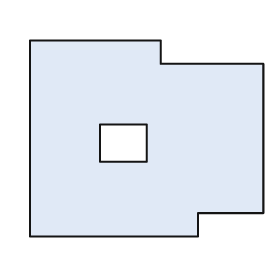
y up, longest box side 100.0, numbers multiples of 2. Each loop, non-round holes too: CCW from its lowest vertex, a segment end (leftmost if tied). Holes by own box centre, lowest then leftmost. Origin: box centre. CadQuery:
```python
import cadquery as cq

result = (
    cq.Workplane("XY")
    .moveTo(-50.0, -42.0)
    .lineTo(22.0, -42.0)
    .lineTo(22.0, -32.0)
    .lineTo(50.0, -32.0)
    .lineTo(50.0, 32.0)
    .lineTo(6.0, 32.0)
    .lineTo(6.0, 42.0)
    .lineTo(-50.0, 42.0)
    .close()
    .moveTo(-20.0, -10.0)
    .lineTo(0.0, -10.0)
    .lineTo(0.0, 6.0)
    .lineTo(-20.0, 6.0)
    .close()
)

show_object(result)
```